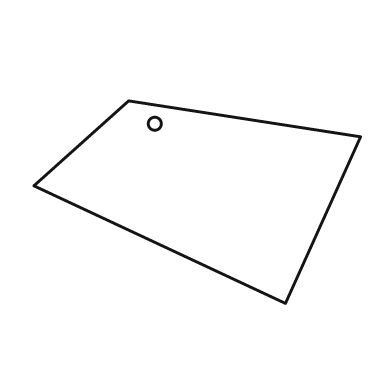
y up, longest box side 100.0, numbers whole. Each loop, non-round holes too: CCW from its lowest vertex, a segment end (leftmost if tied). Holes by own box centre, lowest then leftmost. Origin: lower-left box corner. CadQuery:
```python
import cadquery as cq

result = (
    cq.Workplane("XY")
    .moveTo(77.0, 0.0)
    .lineTo(100.0, 51.0)
    .lineTo(29.0, 62.0)
    .lineTo(0.0, 36.0)
    .close()
    .moveTo(37.0, 55.0)
    .circle(2.0)
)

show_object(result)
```